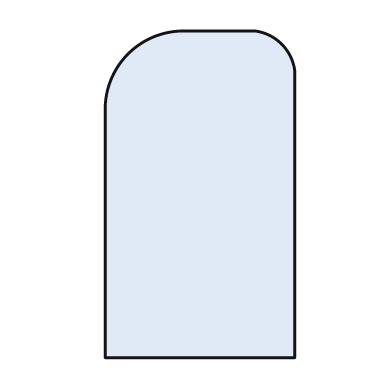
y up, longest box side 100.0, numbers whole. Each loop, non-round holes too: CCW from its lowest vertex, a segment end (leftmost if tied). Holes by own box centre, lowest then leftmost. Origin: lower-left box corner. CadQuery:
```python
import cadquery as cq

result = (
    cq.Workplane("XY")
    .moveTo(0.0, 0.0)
    .lineTo(58.0, 0.0)
    .lineTo(58.0, 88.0)
    .threePointArc((54.0, 96.0), (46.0, 100.0))
    .lineTo(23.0, 100.0)
    .threePointArc((7.0, 93.0), (0.0, 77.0))
    .close()
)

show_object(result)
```